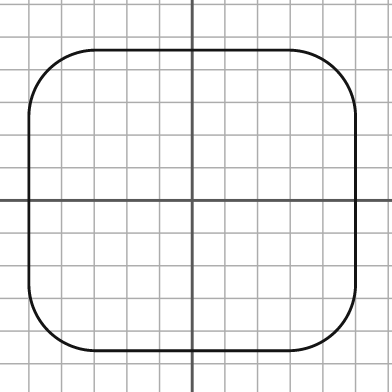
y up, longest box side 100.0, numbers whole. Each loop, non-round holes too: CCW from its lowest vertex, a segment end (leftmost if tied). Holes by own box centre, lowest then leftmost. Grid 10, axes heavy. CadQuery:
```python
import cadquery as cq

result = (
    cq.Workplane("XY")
    .moveTo(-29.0, -46.0)
    .lineTo(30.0, -46.0)
    .threePointArc((44.0, -40.0), (50.0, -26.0))
    .lineTo(50.0, 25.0)
    .threePointArc((44.0, 40.0), (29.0, 46.0))
    .lineTo(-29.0, 46.0)
    .threePointArc((-44.0, 40.0), (-50.0, 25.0))
    .lineTo(-50.0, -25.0)
    .threePointArc((-44.0, -40.0), (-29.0, -46.0))
    .close()
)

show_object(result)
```